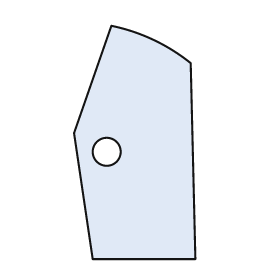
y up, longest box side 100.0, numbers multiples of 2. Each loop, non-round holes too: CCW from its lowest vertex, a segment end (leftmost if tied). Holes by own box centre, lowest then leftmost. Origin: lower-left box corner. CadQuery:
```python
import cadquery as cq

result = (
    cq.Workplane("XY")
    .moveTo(8.0, 0.0)
    .lineTo(52.0, 0.0)
    .lineTo(50.0, 84.0)
    .threePointArc((34.0, 94.0), (16.0, 100.0))
    .lineTo(0.0, 54.0)
    .close()
    .moveTo(14.0, 46.0)
    .circle(6.0)
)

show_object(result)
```